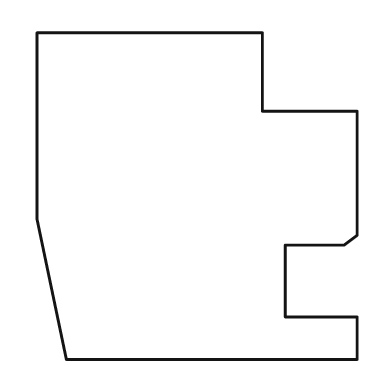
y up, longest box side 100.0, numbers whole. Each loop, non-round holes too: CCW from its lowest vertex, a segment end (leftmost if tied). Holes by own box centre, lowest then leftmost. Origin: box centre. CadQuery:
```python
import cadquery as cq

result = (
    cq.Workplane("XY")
    .moveTo(-40.0, -50.0)
    .lineTo(49.0, -50.0)
    .lineTo(49.0, -37.0)
    .lineTo(27.0, -37.0)
    .lineTo(27.0, -15.0)
    .lineTo(45.0, -15.0)
    .lineTo(49.0, -12.0)
    .lineTo(49.0, 26.0)
    .lineTo(20.0, 26.0)
    .lineTo(20.0, 50.0)
    .lineTo(-49.0, 50.0)
    .lineTo(-49.0, -7.0)
    .close()
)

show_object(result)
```